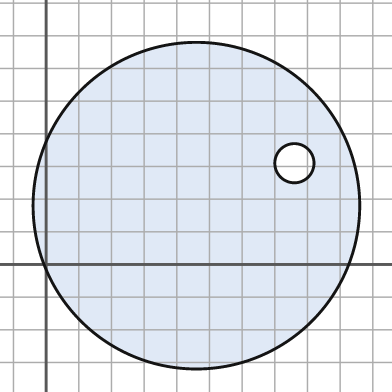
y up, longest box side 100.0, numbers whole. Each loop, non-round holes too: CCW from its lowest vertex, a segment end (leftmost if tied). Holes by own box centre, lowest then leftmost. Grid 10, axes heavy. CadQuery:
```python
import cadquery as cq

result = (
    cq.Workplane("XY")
    .moveTo(46.0, 18.0)
    .circle(50.0)
    .moveTo(76.0, 31.0)
    .circle(6.0)
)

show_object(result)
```